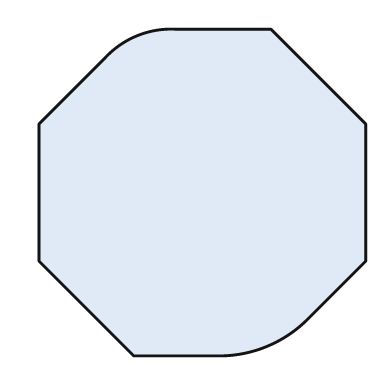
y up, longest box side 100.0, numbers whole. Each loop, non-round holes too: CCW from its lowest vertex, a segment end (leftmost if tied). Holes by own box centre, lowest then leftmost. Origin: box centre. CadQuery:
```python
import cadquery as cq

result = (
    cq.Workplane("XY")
    .moveTo(-21.0, -50.0)
    .lineTo(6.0, -50.0)
    .threePointArc((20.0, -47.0), (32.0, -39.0))
    .lineTo(50.0, -21.0)
    .lineTo(50.0, 21.0)
    .lineTo(21.0, 50.0)
    .lineTo(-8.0, 50.0)
    .threePointArc((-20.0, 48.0), (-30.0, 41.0))
    .lineTo(-50.0, 21.0)
    .lineTo(-50.0, -21.0)
    .close()
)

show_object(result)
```